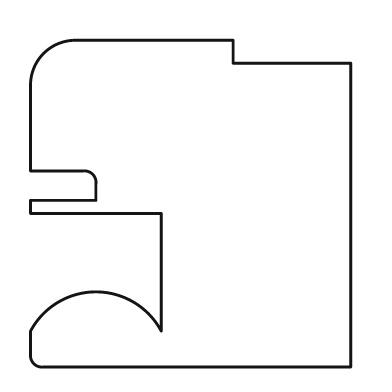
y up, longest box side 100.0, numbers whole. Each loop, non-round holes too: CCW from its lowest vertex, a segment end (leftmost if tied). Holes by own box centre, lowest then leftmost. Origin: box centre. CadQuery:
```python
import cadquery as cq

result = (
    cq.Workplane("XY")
    .moveTo(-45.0, -50.0)
    .lineTo(49.0, -50.0)
    .lineTo(49.0, 43.0)
    .lineTo(13.0, 43.0)
    .lineTo(13.0, 50.0)
    .lineTo(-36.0, 50.0)
    .threePointArc((-45.0, 46.0), (-49.0, 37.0))
    .lineTo(-49.0, 10.0)
    .lineTo(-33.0, 10.0)
    .threePointArc((-30.0, 9.0), (-29.0, 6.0))
    .lineTo(-29.0, 1.0)
    .lineTo(-49.0, 1.0)
    .lineTo(-49.0, -3.0)
    .lineTo(-9.0, -3.0)
    .lineTo(-9.0, -39.0)
    .threePointArc((-29.0, -27.0), (-49.0, -39.0))
    .lineTo(-49.0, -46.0)
    .threePointArc((-48.0, -49.0), (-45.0, -50.0))
    .close()
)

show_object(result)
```